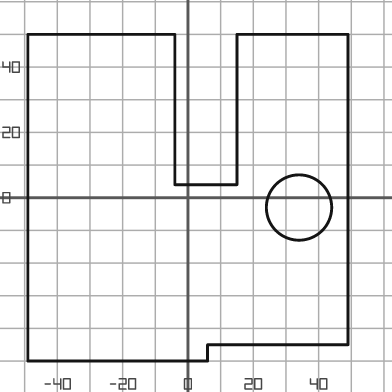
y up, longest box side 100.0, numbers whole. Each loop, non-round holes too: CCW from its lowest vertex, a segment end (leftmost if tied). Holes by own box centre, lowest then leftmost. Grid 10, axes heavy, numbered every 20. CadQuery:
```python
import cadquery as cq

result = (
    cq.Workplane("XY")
    .moveTo(-49.0, -50.0)
    .lineTo(6.0, -50.0)
    .lineTo(6.0, -45.0)
    .lineTo(49.0, -45.0)
    .lineTo(49.0, 50.0)
    .lineTo(15.0, 50.0)
    .lineTo(15.0, 4.0)
    .lineTo(-4.0, 4.0)
    .lineTo(-4.0, 50.0)
    .lineTo(-49.0, 50.0)
    .close()
    .moveTo(34.0, -3.0)
    .circle(10.0)
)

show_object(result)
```